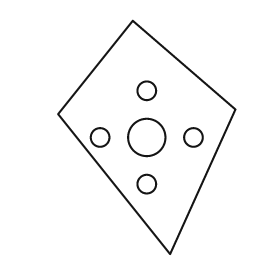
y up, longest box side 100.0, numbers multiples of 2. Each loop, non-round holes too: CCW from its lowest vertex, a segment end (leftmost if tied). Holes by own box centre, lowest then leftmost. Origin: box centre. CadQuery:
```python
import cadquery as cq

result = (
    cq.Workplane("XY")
    .moveTo(10.0, -50.0)
    .lineTo(38.0, 12.0)
    .lineTo(-6.0, 50.0)
    .lineTo(-38.0, 10.0)
    .close()
    .moveTo(0.0, -20.0)
    .circle(4.0)
    .moveTo(-20.0, 0.0)
    .circle(4.0)
    .moveTo(0.0, 0.0)
    .circle(8.0)
    .moveTo(20.0, 0.0)
    .circle(4.0)
    .moveTo(0.0, 20.0)
    .circle(4.0)
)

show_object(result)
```